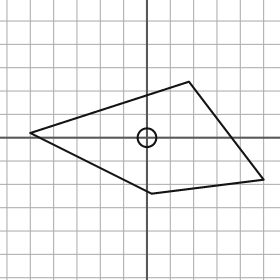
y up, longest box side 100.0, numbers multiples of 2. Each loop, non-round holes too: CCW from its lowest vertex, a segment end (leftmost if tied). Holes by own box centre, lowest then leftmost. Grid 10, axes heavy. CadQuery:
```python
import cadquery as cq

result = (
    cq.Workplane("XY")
    .moveTo(2.0, -24.0)
    .lineTo(50.0, -18.0)
    .lineTo(18.0, 24.0)
    .lineTo(-50.0, 2.0)
    .close()
    .moveTo(0.0, 0.0)
    .circle(4.0)
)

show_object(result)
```